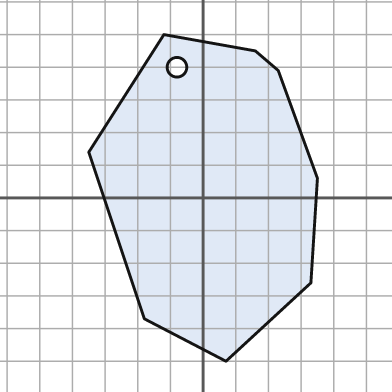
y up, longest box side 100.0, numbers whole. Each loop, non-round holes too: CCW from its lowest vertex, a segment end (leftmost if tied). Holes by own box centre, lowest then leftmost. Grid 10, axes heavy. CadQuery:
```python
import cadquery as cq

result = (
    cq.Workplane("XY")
    .moveTo(7.0, -50.0)
    .lineTo(33.0, -26.0)
    .lineTo(35.0, 6.0)
    .lineTo(23.0, 39.0)
    .lineTo(16.0, 45.0)
    .lineTo(-12.0, 50.0)
    .lineTo(-35.0, 14.0)
    .lineTo(-18.0, -37.0)
    .close()
    .moveTo(-8.0, 40.0)
    .circle(3.0)
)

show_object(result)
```